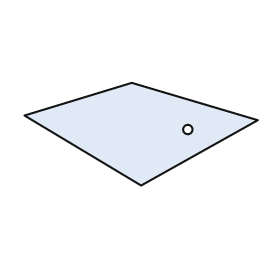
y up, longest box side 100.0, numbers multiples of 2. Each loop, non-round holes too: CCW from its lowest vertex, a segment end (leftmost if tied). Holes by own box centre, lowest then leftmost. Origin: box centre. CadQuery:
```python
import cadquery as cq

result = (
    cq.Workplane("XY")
    .moveTo(0.0, -22.0)
    .lineTo(50.0, 6.0)
    .lineTo(-4.0, 22.0)
    .lineTo(-50.0, 8.0)
    .close()
    .moveTo(20.0, 2.0)
    .circle(2.0)
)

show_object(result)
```